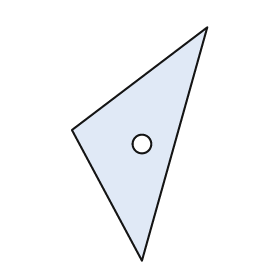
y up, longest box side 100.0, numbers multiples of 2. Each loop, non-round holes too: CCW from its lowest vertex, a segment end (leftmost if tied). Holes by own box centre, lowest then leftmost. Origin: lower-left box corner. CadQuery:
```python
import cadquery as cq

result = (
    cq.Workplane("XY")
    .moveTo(30.0, 0.0)
    .lineTo(58.0, 100.0)
    .lineTo(0.0, 56.0)
    .close()
    .moveTo(30.0, 50.0)
    .circle(4.0)
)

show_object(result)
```